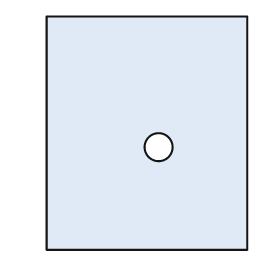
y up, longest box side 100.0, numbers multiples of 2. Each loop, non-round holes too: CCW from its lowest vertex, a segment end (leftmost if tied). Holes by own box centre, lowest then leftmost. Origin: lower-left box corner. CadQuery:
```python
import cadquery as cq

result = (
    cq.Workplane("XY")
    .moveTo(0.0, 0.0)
    .lineTo(86.0, 0.0)
    .lineTo(86.0, 100.0)
    .lineTo(0.0, 100.0)
    .close()
    .moveTo(48.0, 44.0)
    .circle(6.0)
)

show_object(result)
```